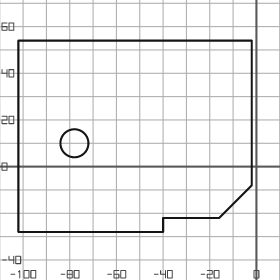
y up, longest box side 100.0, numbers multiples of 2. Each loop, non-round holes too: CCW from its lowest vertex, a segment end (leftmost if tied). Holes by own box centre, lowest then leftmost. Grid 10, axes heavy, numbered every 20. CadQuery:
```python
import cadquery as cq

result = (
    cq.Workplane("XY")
    .moveTo(-102.0, -28.0)
    .lineTo(-40.0, -28.0)
    .lineTo(-40.0, -22.0)
    .lineTo(-16.0, -22.0)
    .lineTo(-2.0, -8.0)
    .lineTo(-2.0, 54.0)
    .lineTo(-102.0, 54.0)
    .close()
    .moveTo(-78.0, 10.0)
    .circle(6.0)
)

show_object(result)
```